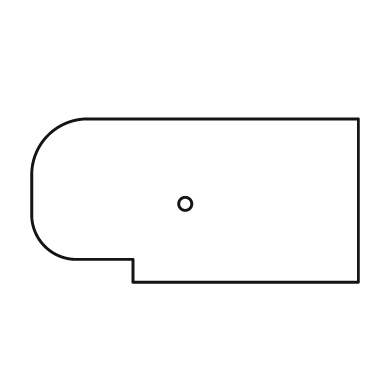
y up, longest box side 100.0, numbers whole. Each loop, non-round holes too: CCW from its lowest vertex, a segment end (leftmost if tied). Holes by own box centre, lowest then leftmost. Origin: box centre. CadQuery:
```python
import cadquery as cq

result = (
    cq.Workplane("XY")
    .moveTo(-19.0, -25.0)
    .lineTo(50.0, -25.0)
    .lineTo(50.0, 25.0)
    .lineTo(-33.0, 25.0)
    .threePointArc((-45.0, 20.0), (-50.0, 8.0))
    .lineTo(-50.0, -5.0)
    .threePointArc((-46.0, -14.0), (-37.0, -18.0))
    .lineTo(-19.0, -18.0)
    .close()
    .moveTo(-3.0, -1.0)
    .circle(2.0)
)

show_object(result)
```